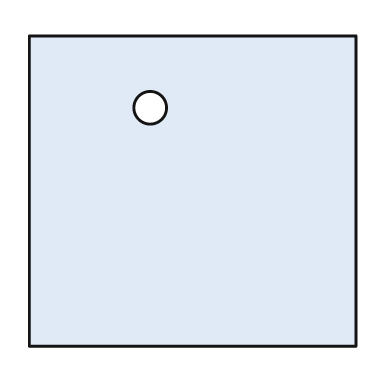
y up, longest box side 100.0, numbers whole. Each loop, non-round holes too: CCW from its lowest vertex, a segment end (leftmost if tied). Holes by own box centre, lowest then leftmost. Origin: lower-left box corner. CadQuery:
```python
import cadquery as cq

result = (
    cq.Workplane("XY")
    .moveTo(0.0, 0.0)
    .lineTo(100.0, 0.0)
    .lineTo(100.0, 95.0)
    .lineTo(0.0, 95.0)
    .close()
    .moveTo(37.0, 73.0)
    .circle(5.0)
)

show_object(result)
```